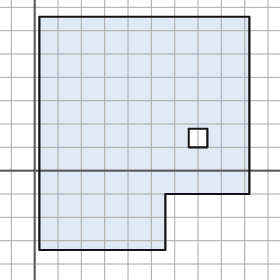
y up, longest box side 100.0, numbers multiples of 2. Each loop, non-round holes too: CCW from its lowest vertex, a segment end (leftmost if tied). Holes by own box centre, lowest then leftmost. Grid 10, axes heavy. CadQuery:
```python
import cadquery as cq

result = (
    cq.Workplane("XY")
    .moveTo(2.0, -34.0)
    .lineTo(56.0, -34.0)
    .lineTo(56.0, -10.0)
    .lineTo(92.0, -10.0)
    .lineTo(92.0, 66.0)
    .lineTo(2.0, 66.0)
    .close()
    .moveTo(66.0, 10.0)
    .lineTo(74.0, 10.0)
    .lineTo(74.0, 18.0)
    .lineTo(66.0, 18.0)
    .close()
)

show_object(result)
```